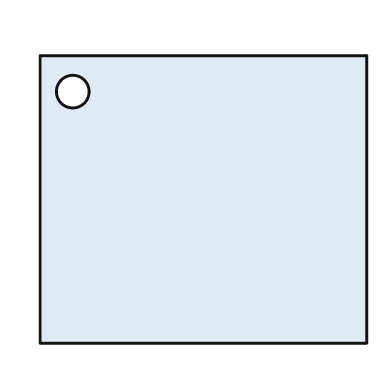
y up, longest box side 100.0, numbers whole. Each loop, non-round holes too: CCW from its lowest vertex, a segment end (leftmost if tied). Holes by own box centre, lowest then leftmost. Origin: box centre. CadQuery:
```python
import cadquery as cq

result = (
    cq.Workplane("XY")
    .moveTo(-50.0, -44.0)
    .lineTo(50.0, -44.0)
    .lineTo(50.0, 44.0)
    .lineTo(-50.0, 44.0)
    .close()
    .moveTo(-40.0, 33.0)
    .circle(5.0)
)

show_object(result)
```